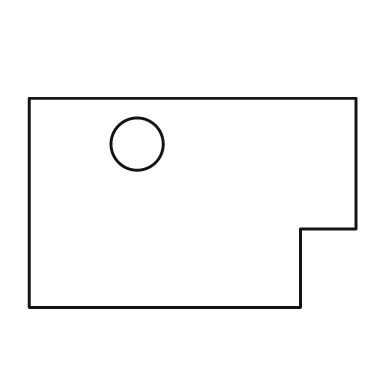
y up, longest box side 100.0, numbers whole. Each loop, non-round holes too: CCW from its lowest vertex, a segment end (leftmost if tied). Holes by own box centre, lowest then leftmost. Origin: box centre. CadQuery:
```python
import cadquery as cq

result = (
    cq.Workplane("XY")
    .moveTo(-50.0, -32.0)
    .lineTo(33.0, -32.0)
    .lineTo(33.0, -8.0)
    .lineTo(50.0, -8.0)
    .lineTo(50.0, 32.0)
    .lineTo(-50.0, 32.0)
    .close()
    .moveTo(-17.0, 18.0)
    .circle(8.0)
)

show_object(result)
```